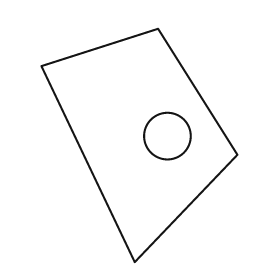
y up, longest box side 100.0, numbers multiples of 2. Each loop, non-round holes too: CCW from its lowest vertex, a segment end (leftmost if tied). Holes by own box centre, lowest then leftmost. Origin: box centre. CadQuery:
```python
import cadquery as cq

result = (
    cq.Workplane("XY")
    .moveTo(-2.0, -50.0)
    .lineTo(42.0, -4.0)
    .lineTo(8.0, 50.0)
    .lineTo(-42.0, 34.0)
    .close()
    .moveTo(12.0, 4.0)
    .circle(10.0)
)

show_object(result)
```